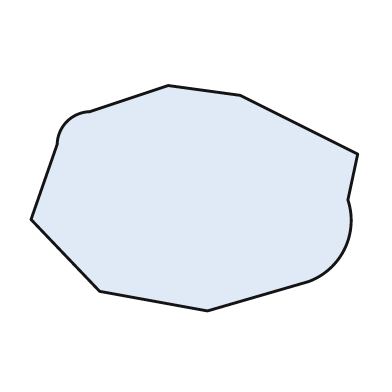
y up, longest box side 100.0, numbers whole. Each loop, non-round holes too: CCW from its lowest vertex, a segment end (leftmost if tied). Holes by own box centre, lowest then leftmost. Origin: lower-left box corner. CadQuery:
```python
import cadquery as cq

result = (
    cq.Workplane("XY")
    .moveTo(54.0, 0.0)
    .lineTo(85.0, 9.0)
    .threePointArc((96.0, 19.0), (97.0, 34.0))
    .lineTo(100.0, 48.0)
    .lineTo(64.0, 66.0)
    .lineTo(42.0, 69.0)
    .lineTo(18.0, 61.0)
    .threePointArc((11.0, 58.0), (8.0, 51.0))
    .lineTo(0.0, 28.0)
    .lineTo(21.0, 6.0)
    .close()
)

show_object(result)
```